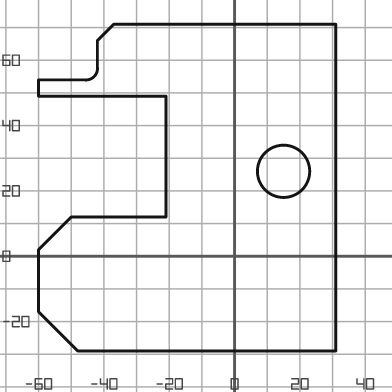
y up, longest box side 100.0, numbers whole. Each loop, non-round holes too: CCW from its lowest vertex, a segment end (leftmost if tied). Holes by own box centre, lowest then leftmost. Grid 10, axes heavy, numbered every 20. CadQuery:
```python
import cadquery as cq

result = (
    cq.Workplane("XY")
    .moveTo(-48.0, -29.0)
    .lineTo(31.0, -29.0)
    .lineTo(31.0, 71.0)
    .lineTo(-37.0, 71.0)
    .lineTo(-42.0, 66.0)
    .lineTo(-42.0, 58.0)
    .threePointArc((-43.0, 55.0), (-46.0, 54.0))
    .lineTo(-60.0, 54.0)
    .lineTo(-60.0, 49.0)
    .lineTo(-21.0, 49.0)
    .lineTo(-21.0, 12.0)
    .lineTo(-50.0, 12.0)
    .lineTo(-60.0, 2.0)
    .lineTo(-60.0, -17.0)
    .close()
    .moveTo(15.0, 26.0)
    .circle(8.0)
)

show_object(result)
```